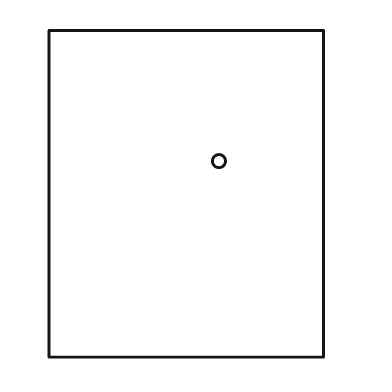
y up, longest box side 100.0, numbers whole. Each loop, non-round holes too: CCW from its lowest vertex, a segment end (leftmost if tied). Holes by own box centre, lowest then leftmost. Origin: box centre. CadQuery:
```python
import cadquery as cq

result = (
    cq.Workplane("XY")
    .moveTo(-42.0, -50.0)
    .lineTo(42.0, -50.0)
    .lineTo(42.0, 50.0)
    .lineTo(-42.0, 50.0)
    .close()
    .moveTo(10.0, 10.0)
    .circle(2.0)
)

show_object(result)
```